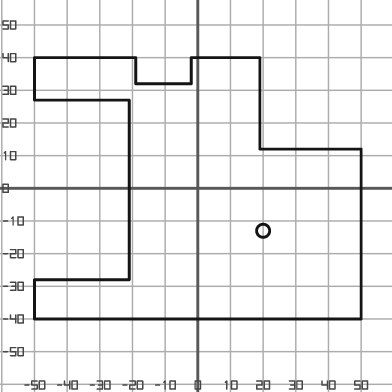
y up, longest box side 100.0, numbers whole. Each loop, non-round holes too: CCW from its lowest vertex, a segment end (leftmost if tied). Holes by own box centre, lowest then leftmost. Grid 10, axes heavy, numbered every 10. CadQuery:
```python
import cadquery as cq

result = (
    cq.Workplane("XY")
    .moveTo(-50.0, -40.0)
    .lineTo(50.0, -40.0)
    .lineTo(50.0, 12.0)
    .lineTo(19.0, 12.0)
    .lineTo(19.0, 40.0)
    .lineTo(-2.0, 40.0)
    .lineTo(-2.0, 32.0)
    .lineTo(-19.0, 32.0)
    .lineTo(-19.0, 40.0)
    .lineTo(-50.0, 40.0)
    .lineTo(-50.0, 27.0)
    .lineTo(-21.0, 27.0)
    .lineTo(-21.0, -28.0)
    .lineTo(-50.0, -28.0)
    .close()
    .moveTo(20.0, -13.0)
    .circle(2.0)
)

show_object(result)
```